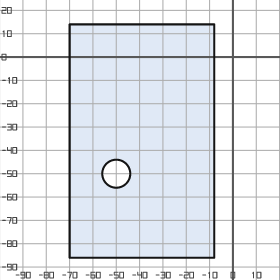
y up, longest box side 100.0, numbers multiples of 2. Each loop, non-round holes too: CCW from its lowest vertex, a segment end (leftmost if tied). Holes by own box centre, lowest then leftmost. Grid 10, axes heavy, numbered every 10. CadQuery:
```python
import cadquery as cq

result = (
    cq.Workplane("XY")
    .moveTo(-70.0, -86.0)
    .lineTo(-8.0, -86.0)
    .lineTo(-8.0, 14.0)
    .lineTo(-70.0, 14.0)
    .close()
    .moveTo(-50.0, -50.0)
    .circle(6.0)
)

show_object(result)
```